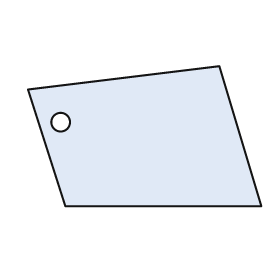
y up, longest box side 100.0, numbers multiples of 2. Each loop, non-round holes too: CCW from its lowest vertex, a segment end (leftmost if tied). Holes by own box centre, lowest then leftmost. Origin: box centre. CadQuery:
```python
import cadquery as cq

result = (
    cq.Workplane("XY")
    .moveTo(-34.0, -30.0)
    .lineTo(50.0, -30.0)
    .lineTo(32.0, 30.0)
    .lineTo(-50.0, 20.0)
    .close()
    .moveTo(-36.0, 6.0)
    .circle(4.0)
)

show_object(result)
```